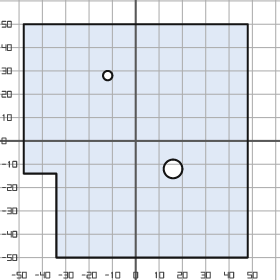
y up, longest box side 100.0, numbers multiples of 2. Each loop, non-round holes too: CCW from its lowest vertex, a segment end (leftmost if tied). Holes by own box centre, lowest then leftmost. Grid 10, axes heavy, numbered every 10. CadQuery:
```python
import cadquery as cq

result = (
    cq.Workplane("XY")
    .moveTo(-34.0, -50.0)
    .lineTo(48.0, -50.0)
    .lineTo(48.0, 50.0)
    .lineTo(-48.0, 50.0)
    .lineTo(-48.0, -14.0)
    .lineTo(-34.0, -14.0)
    .close()
    .moveTo(16.0, -12.0)
    .circle(4.0)
    .moveTo(-12.0, 28.0)
    .circle(2.0)
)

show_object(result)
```